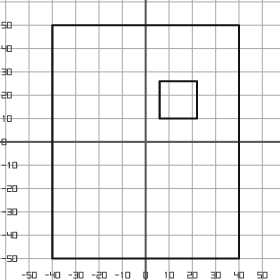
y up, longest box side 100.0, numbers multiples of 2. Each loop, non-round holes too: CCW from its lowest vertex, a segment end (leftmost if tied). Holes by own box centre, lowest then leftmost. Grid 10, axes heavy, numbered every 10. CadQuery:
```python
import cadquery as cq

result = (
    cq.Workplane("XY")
    .moveTo(-40.0, -50.0)
    .lineTo(40.0, -50.0)
    .lineTo(40.0, 50.0)
    .lineTo(-40.0, 50.0)
    .close()
    .moveTo(6.0, 10.0)
    .lineTo(22.0, 10.0)
    .lineTo(22.0, 26.0)
    .lineTo(6.0, 26.0)
    .close()
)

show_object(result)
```